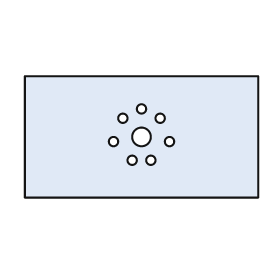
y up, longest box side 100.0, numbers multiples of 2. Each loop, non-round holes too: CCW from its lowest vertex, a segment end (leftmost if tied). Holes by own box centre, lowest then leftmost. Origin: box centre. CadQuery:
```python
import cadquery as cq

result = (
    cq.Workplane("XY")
    .moveTo(-50.0, -26.0)
    .lineTo(50.0, -26.0)
    .lineTo(50.0, 26.0)
    .lineTo(-50.0, 26.0)
    .close()
    .moveTo(-4.0, -10.0)
    .circle(2.0)
    .moveTo(4.0, -10.0)
    .circle(2.0)
    .moveTo(-12.0, -2.0)
    .circle(2.0)
    .moveTo(12.0, -2.0)
    .circle(2.0)
    .moveTo(0.0, 0.0)
    .circle(4.0)
    .moveTo(-8.0, 8.0)
    .circle(2.0)
    .moveTo(8.0, 8.0)
    .circle(2.0)
    .moveTo(0.0, 12.0)
    .circle(2.0)
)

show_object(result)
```